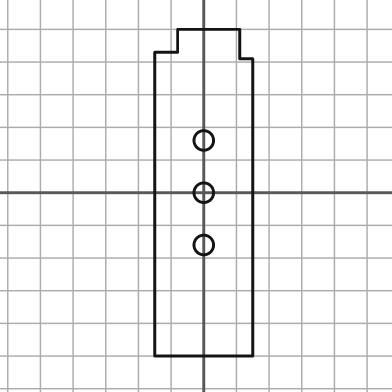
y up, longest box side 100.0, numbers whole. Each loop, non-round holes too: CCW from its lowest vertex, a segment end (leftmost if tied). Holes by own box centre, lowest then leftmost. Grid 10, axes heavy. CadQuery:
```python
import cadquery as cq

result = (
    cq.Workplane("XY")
    .moveTo(-15.0, -50.0)
    .lineTo(15.0, -50.0)
    .lineTo(15.0, 41.0)
    .lineTo(11.0, 41.0)
    .lineTo(11.0, 50.0)
    .lineTo(-8.0, 50.0)
    .lineTo(-8.0, 43.0)
    .lineTo(-15.0, 43.0)
    .close()
    .moveTo(0.0, -16.0)
    .circle(3.0)
    .moveTo(0.0, 0.0)
    .circle(3.0)
    .moveTo(0.0, 16.0)
    .circle(3.0)
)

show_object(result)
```